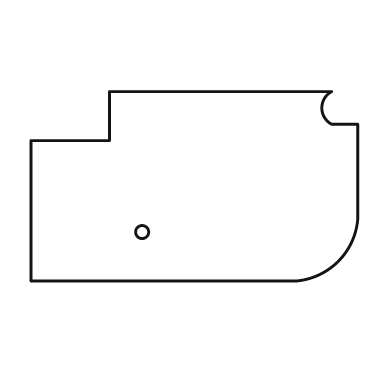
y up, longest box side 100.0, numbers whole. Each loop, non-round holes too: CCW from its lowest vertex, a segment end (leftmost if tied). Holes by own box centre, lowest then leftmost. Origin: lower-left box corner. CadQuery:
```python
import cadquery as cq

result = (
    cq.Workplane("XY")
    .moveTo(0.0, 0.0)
    .lineTo(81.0, 0.0)
    .threePointArc((94.0, 6.0), (100.0, 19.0))
    .lineTo(100.0, 48.0)
    .lineTo(92.0, 48.0)
    .threePointArc((89.0, 53.0), (92.0, 58.0))
    .lineTo(24.0, 58.0)
    .lineTo(24.0, 43.0)
    .lineTo(0.0, 43.0)
    .close()
    .moveTo(34.0, 15.0)
    .circle(2.0)
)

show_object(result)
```